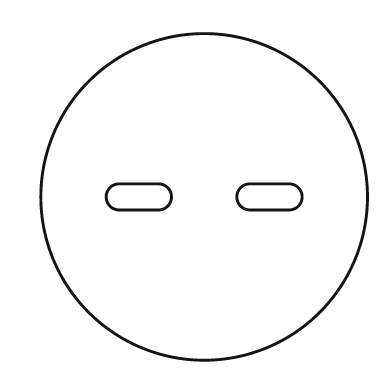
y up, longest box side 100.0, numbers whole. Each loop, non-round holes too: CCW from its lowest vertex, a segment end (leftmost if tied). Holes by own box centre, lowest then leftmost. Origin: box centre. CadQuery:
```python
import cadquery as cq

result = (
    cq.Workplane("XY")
    .moveTo(0.0, 0.0)
    .circle(50.0)
    .moveTo(-26.0, -4.0)
    .lineTo(-14.0, -4.0)
    .threePointArc((-10.0, 0.0), (-14.0, 4.0))
    .lineTo(-26.0, 4.0)
    .threePointArc((-30.0, 0.0), (-26.0, -4.0))
    .close()
    .moveTo(14.0, -4.0)
    .lineTo(26.0, -4.0)
    .threePointArc((30.0, 0.0), (26.0, 4.0))
    .lineTo(14.0, 4.0)
    .threePointArc((10.0, 0.0), (14.0, -4.0))
    .close()
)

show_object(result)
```